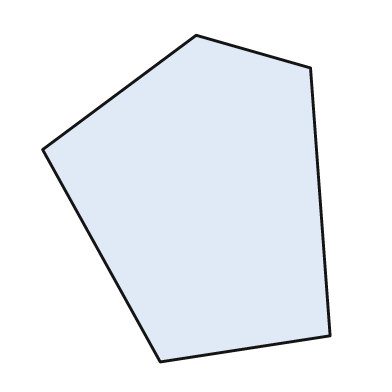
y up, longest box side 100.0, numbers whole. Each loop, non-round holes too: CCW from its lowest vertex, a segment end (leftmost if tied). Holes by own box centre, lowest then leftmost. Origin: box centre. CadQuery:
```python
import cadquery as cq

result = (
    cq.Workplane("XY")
    .moveTo(-8.0, -50.0)
    .lineTo(44.0, -42.0)
    .lineTo(38.0, 40.0)
    .lineTo(3.0, 50.0)
    .lineTo(-44.0, 15.0)
    .close()
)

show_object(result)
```